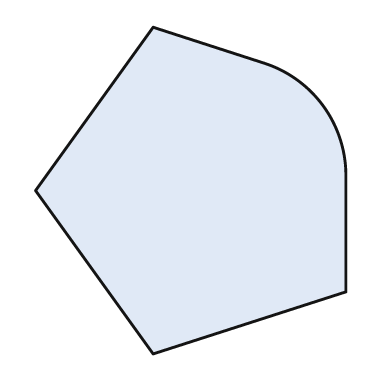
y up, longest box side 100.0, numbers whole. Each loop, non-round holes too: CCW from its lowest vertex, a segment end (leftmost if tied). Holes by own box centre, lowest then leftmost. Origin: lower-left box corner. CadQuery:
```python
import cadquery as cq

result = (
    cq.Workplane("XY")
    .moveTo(36.0, 0.0)
    .lineTo(95.0, 19.0)
    .lineTo(95.0, 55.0)
    .threePointArc((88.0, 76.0), (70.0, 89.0))
    .lineTo(36.0, 100.0)
    .lineTo(0.0, 50.0)
    .close()
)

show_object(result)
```